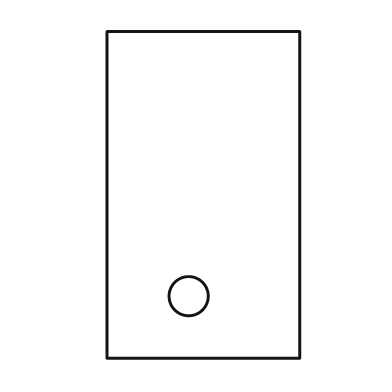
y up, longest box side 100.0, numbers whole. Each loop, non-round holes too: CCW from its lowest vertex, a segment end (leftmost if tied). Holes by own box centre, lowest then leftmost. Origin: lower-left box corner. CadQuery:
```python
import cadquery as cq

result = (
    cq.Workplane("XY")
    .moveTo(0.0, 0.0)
    .lineTo(59.0, 0.0)
    .lineTo(59.0, 100.0)
    .lineTo(0.0, 100.0)
    .close()
    .moveTo(25.0, 19.0)
    .circle(6.0)
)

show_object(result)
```